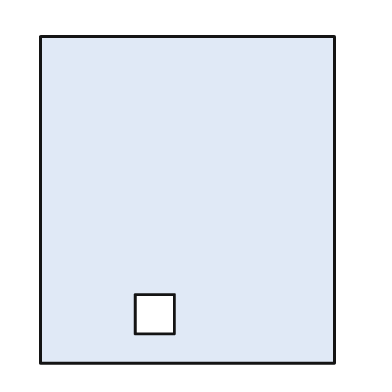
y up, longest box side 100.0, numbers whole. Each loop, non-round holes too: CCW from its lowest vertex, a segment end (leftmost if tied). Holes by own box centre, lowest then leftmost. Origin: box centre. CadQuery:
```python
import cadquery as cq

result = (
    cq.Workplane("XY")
    .moveTo(-45.0, -50.0)
    .lineTo(45.0, -50.0)
    .lineTo(45.0, 50.0)
    .lineTo(-45.0, 50.0)
    .close()
    .moveTo(-16.0, -41.0)
    .lineTo(-4.0, -41.0)
    .lineTo(-4.0, -29.0)
    .lineTo(-16.0, -29.0)
    .close()
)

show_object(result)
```